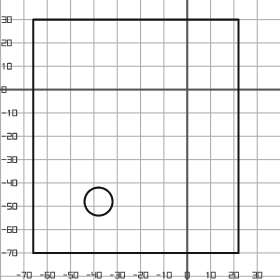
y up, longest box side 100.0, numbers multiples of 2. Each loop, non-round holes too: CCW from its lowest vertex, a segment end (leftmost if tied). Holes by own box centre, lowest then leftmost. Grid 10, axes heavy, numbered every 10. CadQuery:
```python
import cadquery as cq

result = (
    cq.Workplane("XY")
    .moveTo(-66.0, -70.0)
    .lineTo(22.0, -70.0)
    .lineTo(22.0, 30.0)
    .lineTo(-66.0, 30.0)
    .close()
    .moveTo(-38.0, -48.0)
    .circle(6.0)
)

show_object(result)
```